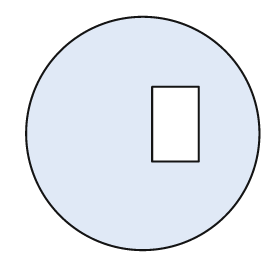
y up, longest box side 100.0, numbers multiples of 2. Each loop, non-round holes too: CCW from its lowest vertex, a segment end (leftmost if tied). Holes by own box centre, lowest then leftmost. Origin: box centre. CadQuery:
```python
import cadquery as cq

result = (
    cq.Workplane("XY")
    .moveTo(0.0, 0.0)
    .circle(50.0)
    .moveTo(4.0, -12.0)
    .lineTo(24.0, -12.0)
    .lineTo(24.0, 20.0)
    .lineTo(4.0, 20.0)
    .close()
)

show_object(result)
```